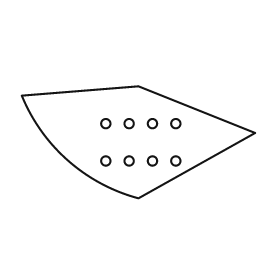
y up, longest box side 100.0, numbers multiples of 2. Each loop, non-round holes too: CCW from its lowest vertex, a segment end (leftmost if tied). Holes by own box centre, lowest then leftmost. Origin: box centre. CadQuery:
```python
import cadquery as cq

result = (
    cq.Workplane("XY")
    .moveTo(0.0, -24.0)
    .lineTo(50.0, 4.0)
    .lineTo(0.0, 24.0)
    .lineTo(-50.0, 20.0)
    .threePointArc((-30.0, -8.0), (0.0, -24.0))
    .close()
    .moveTo(-14.0, -8.0)
    .circle(2.0)
    .moveTo(-4.0, -8.0)
    .circle(2.0)
    .moveTo(6.0, -8.0)
    .circle(2.0)
    .moveTo(16.0, -8.0)
    .circle(2.0)
    .moveTo(-14.0, 8.0)
    .circle(2.0)
    .moveTo(-4.0, 8.0)
    .circle(2.0)
    .moveTo(6.0, 8.0)
    .circle(2.0)
    .moveTo(16.0, 8.0)
    .circle(2.0)
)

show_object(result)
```